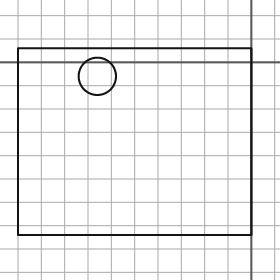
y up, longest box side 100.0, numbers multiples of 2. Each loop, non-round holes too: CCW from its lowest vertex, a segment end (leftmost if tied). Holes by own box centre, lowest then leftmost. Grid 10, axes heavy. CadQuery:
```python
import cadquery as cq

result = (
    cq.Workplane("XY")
    .moveTo(-100.0, -74.0)
    .lineTo(0.0, -74.0)
    .lineTo(0.0, 6.0)
    .lineTo(-100.0, 6.0)
    .close()
    .moveTo(-66.0, -6.0)
    .circle(8.0)
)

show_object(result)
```